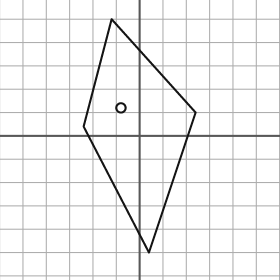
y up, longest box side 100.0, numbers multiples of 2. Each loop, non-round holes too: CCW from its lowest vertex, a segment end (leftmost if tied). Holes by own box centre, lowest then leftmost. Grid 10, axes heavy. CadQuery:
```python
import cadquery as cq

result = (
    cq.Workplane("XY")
    .moveTo(4.0, -50.0)
    .lineTo(24.0, 10.0)
    .lineTo(-12.0, 50.0)
    .lineTo(-24.0, 4.0)
    .close()
    .moveTo(-8.0, 12.0)
    .circle(2.0)
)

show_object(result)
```